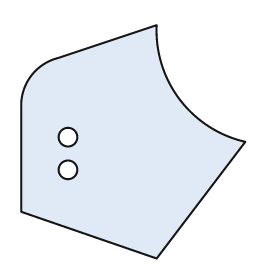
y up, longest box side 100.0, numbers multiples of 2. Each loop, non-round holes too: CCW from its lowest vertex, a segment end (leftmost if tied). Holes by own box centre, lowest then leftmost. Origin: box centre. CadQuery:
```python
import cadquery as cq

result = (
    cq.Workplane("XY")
    .moveTo(10.0, -50.0)
    .lineTo(48.0, 0.0)
    .threePointArc((20.0, 18.0), (10.0, 50.0))
    .lineTo(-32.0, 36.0)
    .threePointArc((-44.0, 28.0), (-48.0, 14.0))
    .lineTo(-48.0, -30.0)
    .close()
    .moveTo(-28.0, -12.0)
    .circle(4.0)
    .moveTo(-28.0, 2.0)
    .circle(4.0)
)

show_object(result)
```